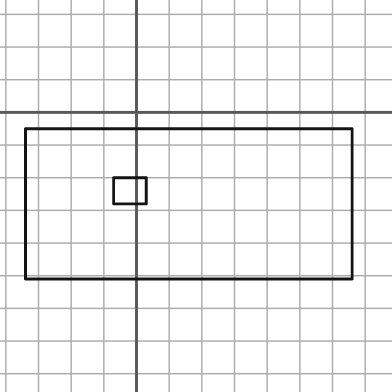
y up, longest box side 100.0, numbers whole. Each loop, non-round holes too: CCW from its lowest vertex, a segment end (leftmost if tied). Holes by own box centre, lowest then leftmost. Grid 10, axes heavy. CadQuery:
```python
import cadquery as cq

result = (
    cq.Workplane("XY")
    .moveTo(-34.0, -51.0)
    .lineTo(66.0, -51.0)
    .lineTo(66.0, -5.0)
    .lineTo(-34.0, -5.0)
    .close()
    .moveTo(-7.0, -28.0)
    .lineTo(3.0, -28.0)
    .lineTo(3.0, -20.0)
    .lineTo(-7.0, -20.0)
    .close()
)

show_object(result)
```